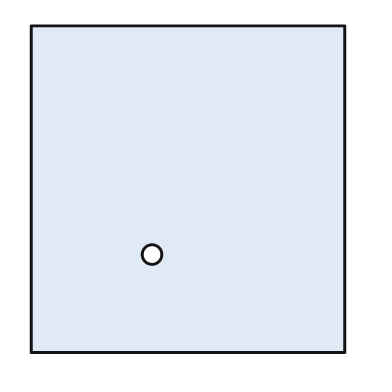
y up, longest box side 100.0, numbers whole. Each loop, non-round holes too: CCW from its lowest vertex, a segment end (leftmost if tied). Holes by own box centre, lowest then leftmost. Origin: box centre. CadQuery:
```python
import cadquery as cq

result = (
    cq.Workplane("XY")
    .moveTo(-48.0, -50.0)
    .lineTo(48.0, -50.0)
    .lineTo(48.0, 50.0)
    .lineTo(-48.0, 50.0)
    .close()
    .moveTo(-11.0, -20.0)
    .circle(3.0)
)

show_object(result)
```